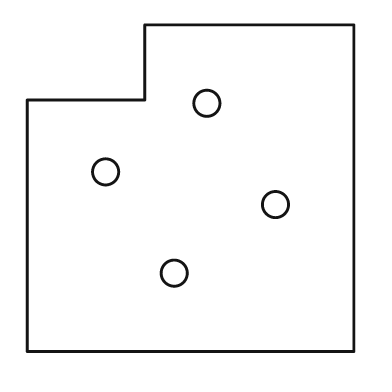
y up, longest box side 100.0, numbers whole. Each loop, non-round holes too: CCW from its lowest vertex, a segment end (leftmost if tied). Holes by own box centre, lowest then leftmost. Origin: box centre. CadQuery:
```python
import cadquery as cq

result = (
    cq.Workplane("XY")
    .moveTo(-50.0, -50.0)
    .lineTo(50.0, -50.0)
    .lineTo(50.0, 50.0)
    .lineTo(-14.0, 50.0)
    .lineTo(-14.0, 27.0)
    .lineTo(-50.0, 27.0)
    .close()
    .moveTo(-5.0, -26.0)
    .circle(4.0)
    .moveTo(26.0, -5.0)
    .circle(4.0)
    .moveTo(-26.0, 5.0)
    .circle(4.0)
    .moveTo(5.0, 26.0)
    .circle(4.0)
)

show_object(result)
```